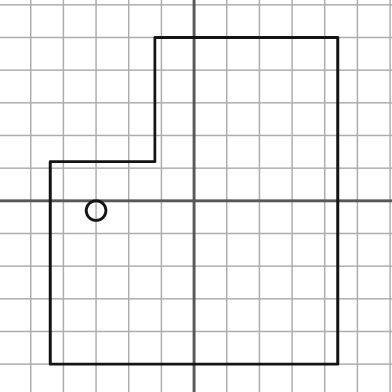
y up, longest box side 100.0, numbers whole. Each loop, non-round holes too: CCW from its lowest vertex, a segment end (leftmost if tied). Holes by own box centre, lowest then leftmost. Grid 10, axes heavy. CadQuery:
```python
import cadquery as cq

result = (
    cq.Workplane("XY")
    .moveTo(-44.0, -50.0)
    .lineTo(44.0, -50.0)
    .lineTo(44.0, 50.0)
    .lineTo(-12.0, 50.0)
    .lineTo(-12.0, 12.0)
    .lineTo(-44.0, 12.0)
    .close()
    .moveTo(-30.0, -3.0)
    .circle(3.0)
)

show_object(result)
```